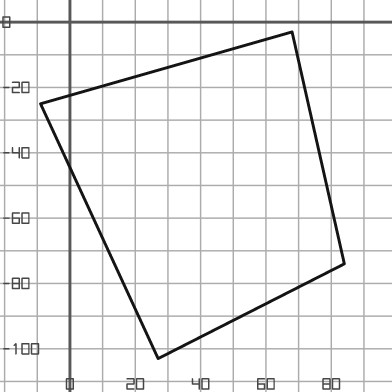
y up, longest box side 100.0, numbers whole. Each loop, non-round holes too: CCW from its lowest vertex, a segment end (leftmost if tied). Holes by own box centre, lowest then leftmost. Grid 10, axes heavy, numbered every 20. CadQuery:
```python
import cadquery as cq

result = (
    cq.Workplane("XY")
    .moveTo(27.0, -103.0)
    .lineTo(84.0, -74.0)
    .lineTo(68.0, -3.0)
    .lineTo(-9.0, -25.0)
    .close()
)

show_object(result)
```